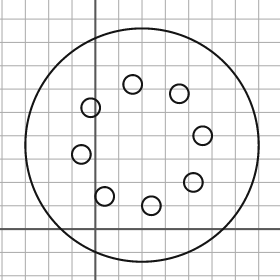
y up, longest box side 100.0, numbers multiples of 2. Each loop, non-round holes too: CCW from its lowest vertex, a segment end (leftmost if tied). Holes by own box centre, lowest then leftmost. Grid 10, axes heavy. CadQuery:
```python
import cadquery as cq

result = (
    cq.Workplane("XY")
    .moveTo(20.0, 36.0)
    .circle(50.0)
    .moveTo(24.0, 10.0)
    .circle(4.0)
    .moveTo(4.0, 14.0)
    .circle(4.0)
    .moveTo(42.0, 20.0)
    .circle(4.0)
    .moveTo(-6.0, 32.0)
    .circle(4.0)
    .moveTo(46.0, 40.0)
    .circle(4.0)
    .moveTo(-2.0, 52.0)
    .circle(4.0)
    .moveTo(36.0, 58.0)
    .circle(4.0)
    .moveTo(16.0, 62.0)
    .circle(4.0)
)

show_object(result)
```